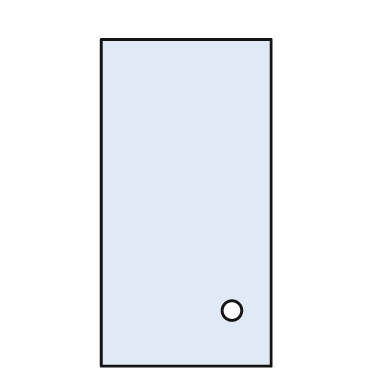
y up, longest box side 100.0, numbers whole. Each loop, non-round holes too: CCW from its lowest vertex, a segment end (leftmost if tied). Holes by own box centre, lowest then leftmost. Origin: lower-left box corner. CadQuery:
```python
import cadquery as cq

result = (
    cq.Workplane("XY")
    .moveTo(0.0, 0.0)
    .lineTo(52.0, 0.0)
    .lineTo(52.0, 100.0)
    .lineTo(0.0, 100.0)
    .close()
    .moveTo(40.0, 17.0)
    .circle(3.0)
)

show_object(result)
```